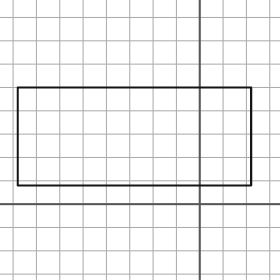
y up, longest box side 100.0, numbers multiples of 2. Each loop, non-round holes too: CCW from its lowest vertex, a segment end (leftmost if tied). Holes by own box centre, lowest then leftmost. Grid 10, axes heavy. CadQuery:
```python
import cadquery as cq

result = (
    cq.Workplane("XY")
    .moveTo(-78.0, 8.0)
    .lineTo(22.0, 8.0)
    .lineTo(22.0, 50.0)
    .lineTo(-78.0, 50.0)
    .close()
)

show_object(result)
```